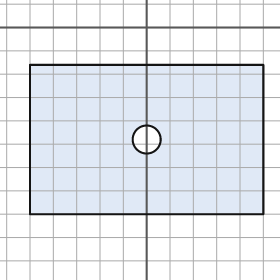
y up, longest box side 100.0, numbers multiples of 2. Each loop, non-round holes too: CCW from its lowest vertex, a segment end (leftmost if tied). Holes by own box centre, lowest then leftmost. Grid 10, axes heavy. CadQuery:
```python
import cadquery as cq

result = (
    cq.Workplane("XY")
    .moveTo(-50.0, -80.0)
    .lineTo(50.0, -80.0)
    .lineTo(50.0, -16.0)
    .lineTo(-50.0, -16.0)
    .close()
    .moveTo(0.0, -48.0)
    .circle(6.0)
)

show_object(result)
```